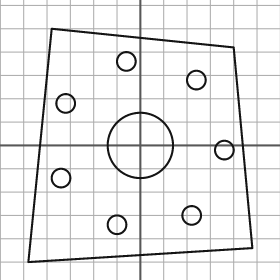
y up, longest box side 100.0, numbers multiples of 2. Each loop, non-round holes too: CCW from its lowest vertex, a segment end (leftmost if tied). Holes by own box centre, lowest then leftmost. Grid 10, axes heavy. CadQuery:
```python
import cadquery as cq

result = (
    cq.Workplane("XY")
    .moveTo(-48.0, -50.0)
    .lineTo(48.0, -44.0)
    .lineTo(40.0, 42.0)
    .lineTo(-38.0, 50.0)
    .close()
    .moveTo(-10.0, -34.0)
    .circle(4.0)
    .moveTo(22.0, -30.0)
    .circle(4.0)
    .moveTo(-34.0, -14.0)
    .circle(4.0)
    .moveTo(36.0, -2.0)
    .circle(4.0)
    .moveTo(0.0, 0.0)
    .circle(14.0)
    .moveTo(-32.0, 18.0)
    .circle(4.0)
    .moveTo(24.0, 28.0)
    .circle(4.0)
    .moveTo(-6.0, 36.0)
    .circle(4.0)
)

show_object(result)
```